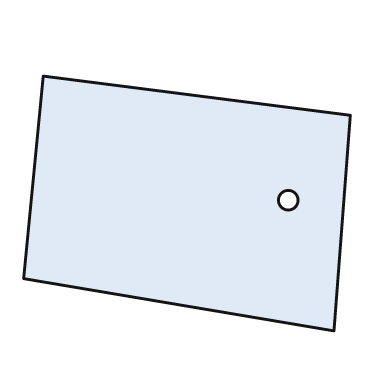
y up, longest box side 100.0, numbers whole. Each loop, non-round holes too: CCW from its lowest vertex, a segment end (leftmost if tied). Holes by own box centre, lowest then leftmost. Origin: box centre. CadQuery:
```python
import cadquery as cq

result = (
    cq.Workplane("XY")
    .moveTo(45.0, -39.0)
    .lineTo(50.0, 27.0)
    .lineTo(-44.0, 39.0)
    .lineTo(-50.0, -23.0)
    .close()
    .moveTo(31.0, 1.0)
    .circle(3.0)
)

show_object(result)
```